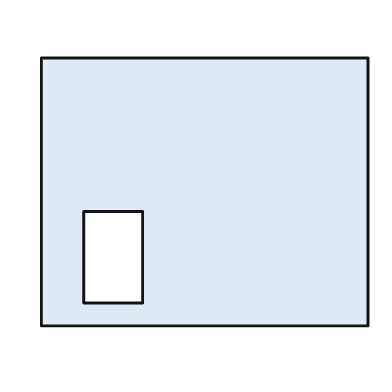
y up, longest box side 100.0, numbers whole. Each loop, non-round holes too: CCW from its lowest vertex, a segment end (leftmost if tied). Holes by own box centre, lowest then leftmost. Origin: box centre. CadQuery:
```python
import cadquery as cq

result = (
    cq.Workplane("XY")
    .moveTo(-50.0, -41.0)
    .lineTo(50.0, -41.0)
    .lineTo(50.0, 41.0)
    .lineTo(-50.0, 41.0)
    .close()
    .moveTo(-37.0, -34.0)
    .lineTo(-19.0, -34.0)
    .lineTo(-19.0, -6.0)
    .lineTo(-37.0, -6.0)
    .close()
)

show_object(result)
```